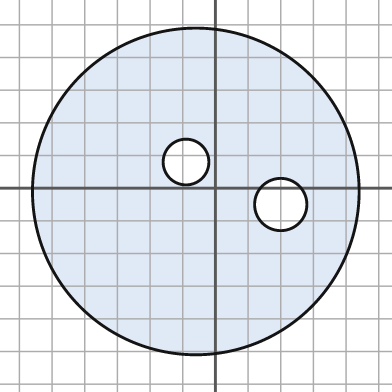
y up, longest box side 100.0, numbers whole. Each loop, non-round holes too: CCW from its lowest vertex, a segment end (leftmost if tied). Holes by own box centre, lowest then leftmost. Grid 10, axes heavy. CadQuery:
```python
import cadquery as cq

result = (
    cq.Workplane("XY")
    .moveTo(-6.0, -1.0)
    .circle(50.0)
    .moveTo(20.0, -5.0)
    .circle(8.0)
    .moveTo(-9.0, 8.0)
    .circle(7.0)
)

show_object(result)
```